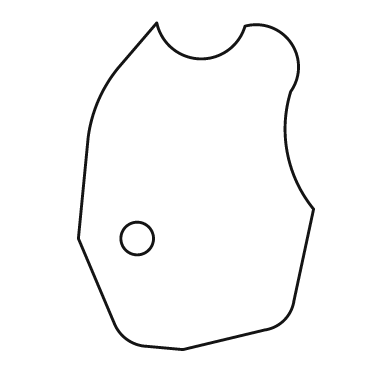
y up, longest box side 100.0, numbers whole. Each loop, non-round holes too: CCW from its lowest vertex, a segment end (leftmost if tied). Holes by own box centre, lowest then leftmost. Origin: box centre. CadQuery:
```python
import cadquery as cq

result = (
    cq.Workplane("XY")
    .moveTo(-4.0, -50.0)
    .lineTo(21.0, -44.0)
    .threePointArc((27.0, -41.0), (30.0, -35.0))
    .lineTo(36.0, -7.0)
    .threePointArc((28.0, 10.0), (29.0, 29.0))
    .threePointArc((29.0, 44.0), (15.0, 49.0))
    .threePointArc((1.0, 39.0), (-12.0, 50.0))
    .lineTo(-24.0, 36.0)
    .threePointArc((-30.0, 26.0), (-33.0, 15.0))
    .lineTo(-36.0, -16.0)
    .lineTo(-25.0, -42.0)
    .threePointArc((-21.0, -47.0), (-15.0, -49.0))
    .close()
    .moveTo(-18.0, -16.0)
    .circle(5.0)
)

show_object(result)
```